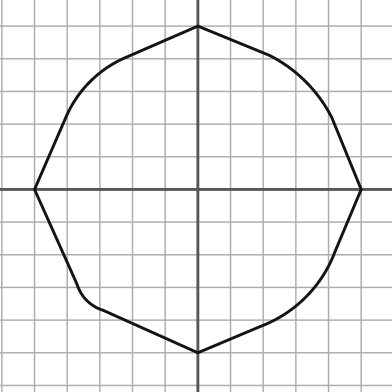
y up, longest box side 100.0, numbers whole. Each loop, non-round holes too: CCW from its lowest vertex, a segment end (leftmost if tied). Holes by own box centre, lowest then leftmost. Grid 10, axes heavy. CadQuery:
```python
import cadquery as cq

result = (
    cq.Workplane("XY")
    .moveTo(0.0, -50.0)
    .lineTo(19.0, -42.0)
    .threePointArc((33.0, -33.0), (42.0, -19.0))
    .lineTo(50.0, 0.0)
    .lineTo(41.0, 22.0)
    .threePointArc((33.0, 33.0), (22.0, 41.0))
    .lineTo(0.0, 50.0)
    .lineTo(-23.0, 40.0)
    .threePointArc((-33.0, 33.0), (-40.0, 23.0))
    .lineTo(-50.0, 0.0)
    .lineTo(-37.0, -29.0)
    .threePointArc((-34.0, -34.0), (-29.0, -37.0))
    .close()
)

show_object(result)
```